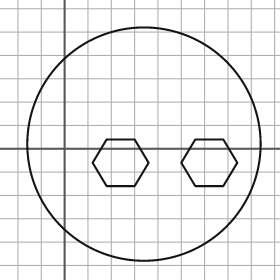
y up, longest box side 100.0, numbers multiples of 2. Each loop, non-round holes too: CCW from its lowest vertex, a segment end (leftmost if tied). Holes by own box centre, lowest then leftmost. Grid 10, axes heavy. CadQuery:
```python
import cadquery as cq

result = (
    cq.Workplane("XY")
    .moveTo(34.0, 2.0)
    .circle(50.0)
    .moveTo(18.0, -16.0)
    .lineTo(30.0, -16.0)
    .lineTo(36.0, -6.0)
    .lineTo(30.0, 4.0)
    .lineTo(18.0, 4.0)
    .lineTo(12.0, -6.0)
    .close()
    .moveTo(56.0, -16.0)
    .lineTo(68.0, -16.0)
    .lineTo(74.0, -6.0)
    .lineTo(68.0, 4.0)
    .lineTo(56.0, 4.0)
    .lineTo(50.0, -6.0)
    .close()
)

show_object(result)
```